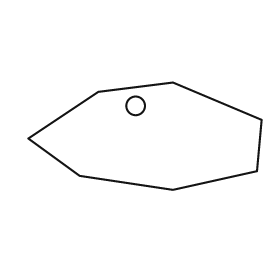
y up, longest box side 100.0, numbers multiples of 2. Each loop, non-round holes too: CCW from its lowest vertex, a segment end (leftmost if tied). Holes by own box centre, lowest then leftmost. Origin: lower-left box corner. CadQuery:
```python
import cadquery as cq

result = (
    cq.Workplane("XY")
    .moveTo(62.0, 0.0)
    .lineTo(98.0, 8.0)
    .lineTo(100.0, 30.0)
    .lineTo(62.0, 46.0)
    .lineTo(30.0, 42.0)
    .lineTo(0.0, 22.0)
    .lineTo(22.0, 6.0)
    .close()
    .moveTo(46.0, 36.0)
    .circle(4.0)
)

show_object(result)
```